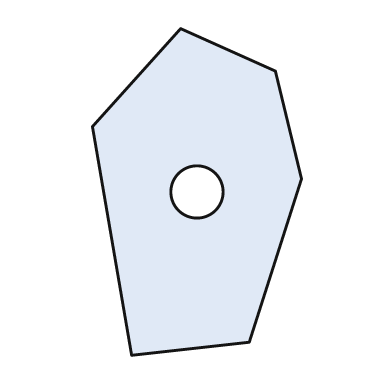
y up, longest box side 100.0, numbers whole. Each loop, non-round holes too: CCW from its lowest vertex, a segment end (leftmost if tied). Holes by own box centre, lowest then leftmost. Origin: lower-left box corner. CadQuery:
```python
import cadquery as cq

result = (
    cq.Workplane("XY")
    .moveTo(12.0, 0.0)
    .lineTo(48.0, 4.0)
    .lineTo(64.0, 54.0)
    .lineTo(56.0, 87.0)
    .lineTo(27.0, 100.0)
    .lineTo(0.0, 70.0)
    .close()
    .moveTo(32.0, 50.0)
    .circle(8.0)
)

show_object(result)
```